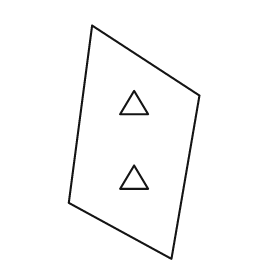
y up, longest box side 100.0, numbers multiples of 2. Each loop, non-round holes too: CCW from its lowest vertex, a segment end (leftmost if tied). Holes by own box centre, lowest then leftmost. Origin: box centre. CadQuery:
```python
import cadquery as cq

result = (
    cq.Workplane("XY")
    .moveTo(16.0, -50.0)
    .lineTo(28.0, 20.0)
    .lineTo(-18.0, 50.0)
    .lineTo(-28.0, -26.0)
    .close()
    .moveTo(-6.0, -20.0)
    .lineTo(6.0, -20.0)
    .lineTo(0.0, -10.0)
    .close()
    .moveTo(-6.0, 12.0)
    .lineTo(6.0, 12.0)
    .lineTo(0.0, 22.0)
    .close()
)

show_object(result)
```